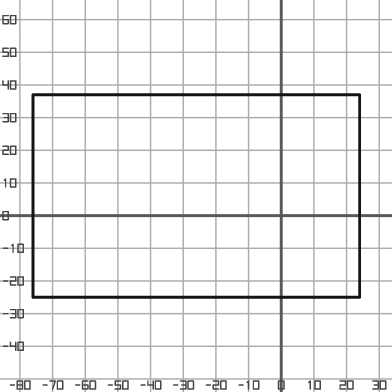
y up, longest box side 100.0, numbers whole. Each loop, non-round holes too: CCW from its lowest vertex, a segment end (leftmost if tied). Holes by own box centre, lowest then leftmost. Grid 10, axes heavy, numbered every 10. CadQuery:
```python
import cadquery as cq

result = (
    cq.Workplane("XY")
    .moveTo(-76.0, -25.0)
    .lineTo(24.0, -25.0)
    .lineTo(24.0, 37.0)
    .lineTo(-76.0, 37.0)
    .close()
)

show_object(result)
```